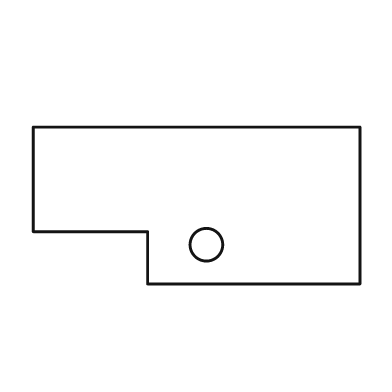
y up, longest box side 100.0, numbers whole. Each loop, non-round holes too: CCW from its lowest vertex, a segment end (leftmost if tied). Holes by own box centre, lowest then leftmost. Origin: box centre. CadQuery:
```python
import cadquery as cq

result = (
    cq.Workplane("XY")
    .moveTo(-15.0, -24.0)
    .lineTo(50.0, -24.0)
    .lineTo(50.0, 24.0)
    .lineTo(-50.0, 24.0)
    .lineTo(-50.0, -8.0)
    .lineTo(-15.0, -8.0)
    .close()
    .moveTo(3.0, -12.0)
    .circle(5.0)
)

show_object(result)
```